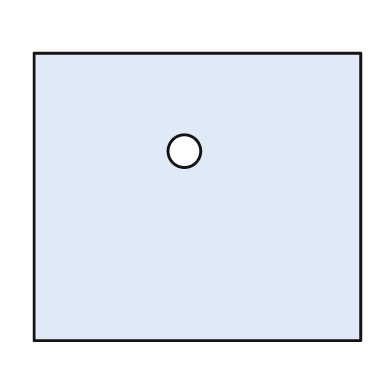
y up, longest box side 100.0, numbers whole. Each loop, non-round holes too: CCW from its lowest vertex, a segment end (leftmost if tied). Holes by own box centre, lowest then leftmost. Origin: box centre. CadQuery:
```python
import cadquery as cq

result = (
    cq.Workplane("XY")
    .moveTo(-50.0, -44.0)
    .lineTo(50.0, -44.0)
    .lineTo(50.0, 44.0)
    .lineTo(-50.0, 44.0)
    .close()
    .moveTo(-4.0, 14.0)
    .circle(5.0)
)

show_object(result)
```